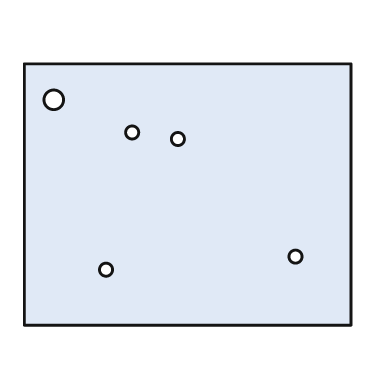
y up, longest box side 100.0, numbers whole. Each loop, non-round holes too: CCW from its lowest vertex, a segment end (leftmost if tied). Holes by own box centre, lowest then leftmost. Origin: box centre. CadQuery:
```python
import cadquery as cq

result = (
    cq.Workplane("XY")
    .moveTo(-50.0, -40.0)
    .lineTo(50.0, -40.0)
    .lineTo(50.0, 40.0)
    .lineTo(-50.0, 40.0)
    .close()
    .moveTo(-25.0, -23.0)
    .circle(2.0)
    .moveTo(33.0, -19.0)
    .circle(2.0)
    .moveTo(-3.0, 17.0)
    .circle(2.0)
    .moveTo(-17.0, 19.0)
    .circle(2.0)
    .moveTo(-41.0, 29.0)
    .circle(3.0)
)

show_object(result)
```